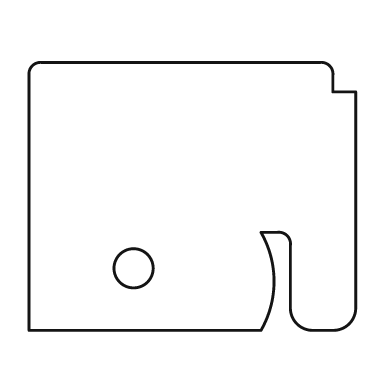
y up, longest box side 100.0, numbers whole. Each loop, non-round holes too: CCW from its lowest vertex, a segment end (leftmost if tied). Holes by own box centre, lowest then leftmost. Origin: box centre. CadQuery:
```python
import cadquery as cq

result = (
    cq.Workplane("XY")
    .moveTo(-50.0, -41.0)
    .lineTo(21.0, -41.0)
    .threePointArc((25.0, -26.0), (21.0, -11.0))
    .lineTo(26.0, -11.0)
    .threePointArc((29.0, -12.0), (30.0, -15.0))
    .lineTo(30.0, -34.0)
    .threePointArc((32.0, -39.0), (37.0, -41.0))
    .lineTo(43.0, -41.0)
    .threePointArc((48.0, -39.0), (50.0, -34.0))
    .lineTo(50.0, 32.0)
    .lineTo(43.0, 32.0)
    .lineTo(43.0, 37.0)
    .threePointArc((42.0, 40.0), (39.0, 41.0))
    .lineTo(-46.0, 41.0)
    .threePointArc((-49.0, 40.0), (-50.0, 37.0))
    .close()
    .moveTo(-18.0, -22.0)
    .circle(6.0)
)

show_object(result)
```